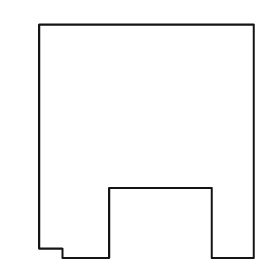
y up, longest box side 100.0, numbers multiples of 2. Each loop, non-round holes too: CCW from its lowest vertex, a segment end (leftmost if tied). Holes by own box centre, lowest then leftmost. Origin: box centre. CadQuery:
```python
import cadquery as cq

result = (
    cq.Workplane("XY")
    .moveTo(-36.0, -50.0)
    .lineTo(-16.0, -50.0)
    .lineTo(-16.0, -20.0)
    .lineTo(28.0, -20.0)
    .lineTo(28.0, -50.0)
    .lineTo(46.0, -50.0)
    .lineTo(46.0, 50.0)
    .lineTo(-46.0, 50.0)
    .lineTo(-46.0, -46.0)
    .lineTo(-36.0, -46.0)
    .close()
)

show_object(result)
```